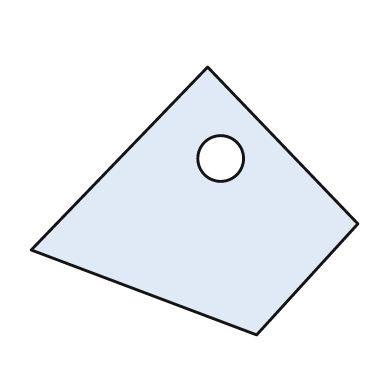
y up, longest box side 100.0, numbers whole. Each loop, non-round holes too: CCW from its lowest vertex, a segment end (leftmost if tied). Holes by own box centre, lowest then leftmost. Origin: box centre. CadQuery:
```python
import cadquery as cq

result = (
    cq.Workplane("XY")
    .moveTo(19.0, -41.0)
    .lineTo(50.0, -7.0)
    .lineTo(4.0, 41.0)
    .lineTo(-50.0, -15.0)
    .close()
    .moveTo(8.0, 13.0)
    .circle(7.0)
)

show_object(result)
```